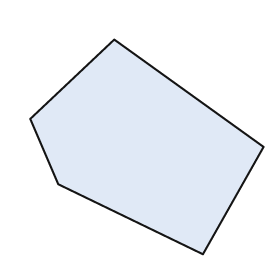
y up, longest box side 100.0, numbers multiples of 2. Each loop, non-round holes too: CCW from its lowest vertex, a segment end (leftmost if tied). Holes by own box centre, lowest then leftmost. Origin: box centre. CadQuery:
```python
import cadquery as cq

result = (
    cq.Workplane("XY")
    .moveTo(24.0, -46.0)
    .lineTo(50.0, 0.0)
    .lineTo(-14.0, 46.0)
    .lineTo(-50.0, 12.0)
    .lineTo(-38.0, -16.0)
    .close()
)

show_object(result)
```